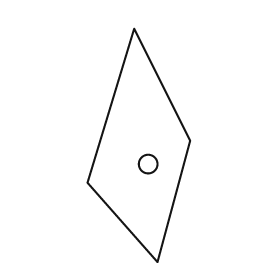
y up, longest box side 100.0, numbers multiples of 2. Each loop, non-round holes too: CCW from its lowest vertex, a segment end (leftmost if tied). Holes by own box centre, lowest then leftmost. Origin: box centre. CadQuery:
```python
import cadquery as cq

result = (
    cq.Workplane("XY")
    .moveTo(8.0, -50.0)
    .lineTo(22.0, 2.0)
    .lineTo(-2.0, 50.0)
    .lineTo(-22.0, -16.0)
    .close()
    .moveTo(4.0, -8.0)
    .circle(4.0)
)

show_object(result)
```